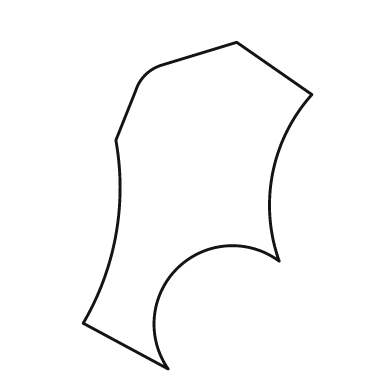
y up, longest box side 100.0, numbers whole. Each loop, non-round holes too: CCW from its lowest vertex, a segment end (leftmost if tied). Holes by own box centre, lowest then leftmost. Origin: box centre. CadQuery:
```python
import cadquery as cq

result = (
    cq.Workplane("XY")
    .moveTo(-9.0, -50.0)
    .threePointArc((-6.0, -19.0), (25.0, -17.0))
    .threePointArc((23.0, 10.0), (35.0, 34.0))
    .lineTo(12.0, 50.0)
    .lineTo(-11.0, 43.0)
    .threePointArc((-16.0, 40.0), (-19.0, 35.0))
    .lineTo(-25.0, 20.0)
    .threePointArc((-25.0, -9.0), (-35.0, -36.0))
    .close()
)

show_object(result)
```